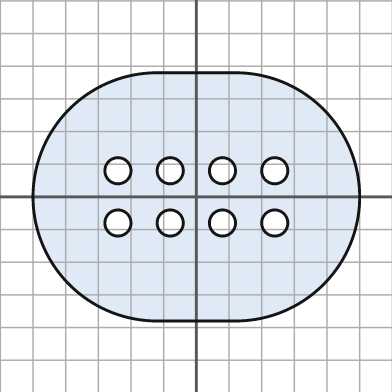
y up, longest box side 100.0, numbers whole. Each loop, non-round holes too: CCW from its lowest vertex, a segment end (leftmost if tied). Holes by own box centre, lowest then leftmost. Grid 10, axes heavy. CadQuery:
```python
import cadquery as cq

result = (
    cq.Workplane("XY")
    .moveTo(-12.0, -38.0)
    .lineTo(12.0, -38.0)
    .threePointArc((50.0, 0.0), (12.0, 38.0))
    .lineTo(-12.0, 38.0)
    .threePointArc((-50.0, 0.0), (-12.0, -38.0))
    .close()
    .moveTo(-24.0, -8.0)
    .circle(4.0)
    .moveTo(-8.0, -8.0)
    .circle(4.0)
    .moveTo(8.0, -8.0)
    .circle(4.0)
    .moveTo(24.0, -8.0)
    .circle(4.0)
    .moveTo(-24.0, 8.0)
    .circle(4.0)
    .moveTo(-8.0, 8.0)
    .circle(4.0)
    .moveTo(8.0, 8.0)
    .circle(4.0)
    .moveTo(24.0, 8.0)
    .circle(4.0)
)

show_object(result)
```